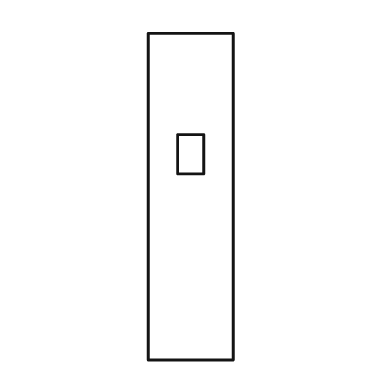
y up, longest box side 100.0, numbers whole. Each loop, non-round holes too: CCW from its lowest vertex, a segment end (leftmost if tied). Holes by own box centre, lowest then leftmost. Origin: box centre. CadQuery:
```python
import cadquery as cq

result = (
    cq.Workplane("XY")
    .moveTo(-13.0, -50.0)
    .lineTo(13.0, -50.0)
    .lineTo(13.0, 50.0)
    .lineTo(-13.0, 50.0)
    .close()
    .moveTo(-4.0, 7.0)
    .lineTo(4.0, 7.0)
    .lineTo(4.0, 19.0)
    .lineTo(-4.0, 19.0)
    .close()
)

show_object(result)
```